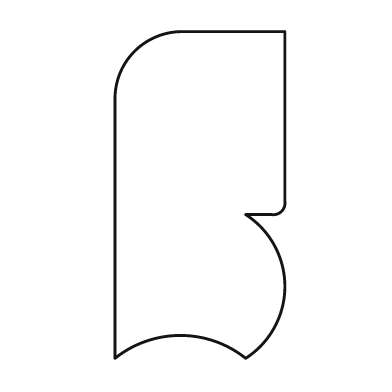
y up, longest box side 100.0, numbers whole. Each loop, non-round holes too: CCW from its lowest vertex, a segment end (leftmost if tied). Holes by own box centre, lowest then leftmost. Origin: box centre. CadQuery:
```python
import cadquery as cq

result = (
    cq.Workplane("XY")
    .moveTo(-26.0, -50.0)
    .threePointArc((-6.0, -43.0), (14.0, -50.0))
    .threePointArc((26.0, -28.0), (14.0, -6.0))
    .lineTo(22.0, -6.0)
    .threePointArc((25.0, -5.0), (26.0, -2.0))
    .lineTo(26.0, 50.0)
    .lineTo(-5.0, 50.0)
    .threePointArc((-20.0, 44.0), (-26.0, 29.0))
    .close()
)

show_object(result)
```